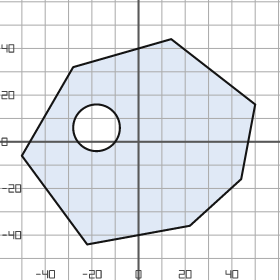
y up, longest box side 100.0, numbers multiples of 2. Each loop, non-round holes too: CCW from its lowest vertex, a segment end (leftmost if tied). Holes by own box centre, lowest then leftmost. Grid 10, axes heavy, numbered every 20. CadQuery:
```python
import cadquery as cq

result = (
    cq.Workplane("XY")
    .moveTo(-22.0, -44.0)
    .lineTo(22.0, -36.0)
    .lineTo(44.0, -16.0)
    .lineTo(50.0, 16.0)
    .lineTo(14.0, 44.0)
    .lineTo(-28.0, 32.0)
    .lineTo(-50.0, -6.0)
    .close()
    .moveTo(-18.0, 6.0)
    .circle(10.0)
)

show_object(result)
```